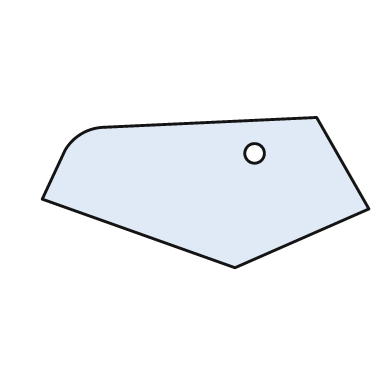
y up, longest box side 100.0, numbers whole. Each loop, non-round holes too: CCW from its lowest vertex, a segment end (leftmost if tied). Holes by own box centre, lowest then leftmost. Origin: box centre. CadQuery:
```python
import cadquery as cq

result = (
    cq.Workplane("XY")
    .moveTo(9.0, -23.0)
    .lineTo(50.0, -5.0)
    .lineTo(34.0, 23.0)
    .lineTo(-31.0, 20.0)
    .threePointArc((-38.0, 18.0), (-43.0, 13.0))
    .lineTo(-50.0, -2.0)
    .close()
    .moveTo(15.0, 12.0)
    .circle(3.0)
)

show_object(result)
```